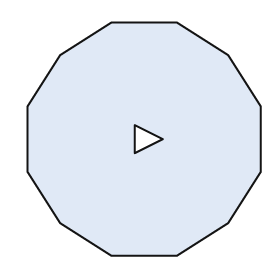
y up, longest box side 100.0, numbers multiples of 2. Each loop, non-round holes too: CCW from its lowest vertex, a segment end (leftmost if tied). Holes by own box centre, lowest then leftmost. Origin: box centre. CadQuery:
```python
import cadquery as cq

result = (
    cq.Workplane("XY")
    .moveTo(-14.0, -50.0)
    .lineTo(14.0, -50.0)
    .lineTo(36.0, -36.0)
    .lineTo(50.0, -14.0)
    .lineTo(50.0, 14.0)
    .lineTo(36.0, 36.0)
    .lineTo(14.0, 50.0)
    .lineTo(-14.0, 50.0)
    .lineTo(-36.0, 36.0)
    .lineTo(-50.0, 14.0)
    .lineTo(-50.0, -14.0)
    .lineTo(-36.0, -36.0)
    .close()
    .moveTo(-4.0, -6.0)
    .lineTo(8.0, 0.0)
    .lineTo(-4.0, 6.0)
    .close()
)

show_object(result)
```